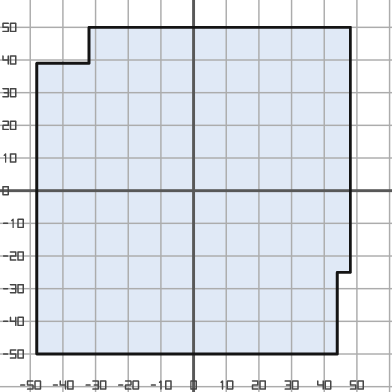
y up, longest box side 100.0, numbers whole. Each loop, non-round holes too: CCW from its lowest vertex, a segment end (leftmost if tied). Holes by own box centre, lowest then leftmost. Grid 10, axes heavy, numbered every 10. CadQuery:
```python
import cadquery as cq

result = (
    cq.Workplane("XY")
    .moveTo(-48.0, -50.0)
    .lineTo(44.0, -50.0)
    .lineTo(44.0, -25.0)
    .lineTo(48.0, -25.0)
    .lineTo(48.0, 50.0)
    .lineTo(-32.0, 50.0)
    .lineTo(-32.0, 39.0)
    .lineTo(-48.0, 39.0)
    .close()
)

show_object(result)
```